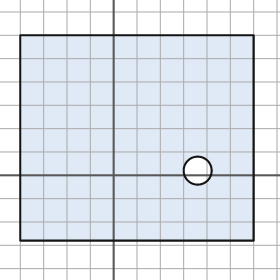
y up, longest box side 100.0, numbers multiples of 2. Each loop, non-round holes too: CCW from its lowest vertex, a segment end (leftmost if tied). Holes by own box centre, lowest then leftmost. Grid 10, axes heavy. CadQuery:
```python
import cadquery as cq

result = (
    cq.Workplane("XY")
    .moveTo(-40.0, -28.0)
    .lineTo(60.0, -28.0)
    .lineTo(60.0, 60.0)
    .lineTo(-40.0, 60.0)
    .close()
    .moveTo(36.0, 2.0)
    .circle(6.0)
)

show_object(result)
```